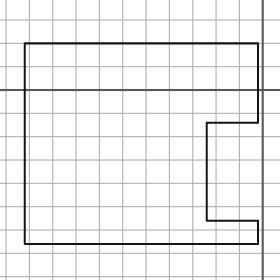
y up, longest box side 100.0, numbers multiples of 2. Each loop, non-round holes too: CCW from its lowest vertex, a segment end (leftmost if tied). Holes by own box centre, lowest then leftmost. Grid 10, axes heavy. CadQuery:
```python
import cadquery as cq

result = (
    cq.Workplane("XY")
    .moveTo(-102.0, -66.0)
    .lineTo(-2.0, -66.0)
    .lineTo(-2.0, -56.0)
    .lineTo(-24.0, -56.0)
    .lineTo(-24.0, -14.0)
    .lineTo(-2.0, -14.0)
    .lineTo(-2.0, 20.0)
    .lineTo(-102.0, 20.0)
    .close()
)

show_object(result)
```